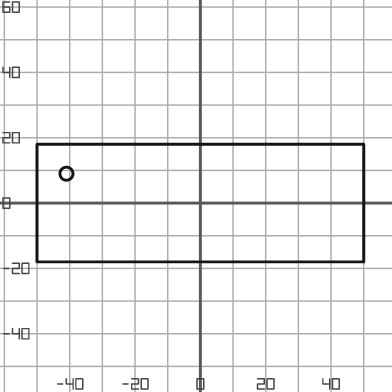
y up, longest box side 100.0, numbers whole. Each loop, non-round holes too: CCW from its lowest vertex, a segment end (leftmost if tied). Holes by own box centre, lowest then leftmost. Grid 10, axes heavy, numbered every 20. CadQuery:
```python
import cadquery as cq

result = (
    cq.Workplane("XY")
    .moveTo(-50.0, -18.0)
    .lineTo(50.0, -18.0)
    .lineTo(50.0, 18.0)
    .lineTo(-50.0, 18.0)
    .close()
    .moveTo(-41.0, 9.0)
    .circle(2.0)
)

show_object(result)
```